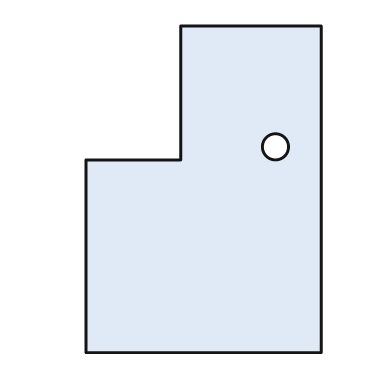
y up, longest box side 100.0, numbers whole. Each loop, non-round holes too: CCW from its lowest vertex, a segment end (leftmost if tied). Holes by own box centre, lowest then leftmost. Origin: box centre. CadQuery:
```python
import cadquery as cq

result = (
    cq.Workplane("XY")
    .moveTo(-36.0, -50.0)
    .lineTo(36.0, -50.0)
    .lineTo(36.0, 50.0)
    .lineTo(-7.0, 50.0)
    .lineTo(-7.0, 9.0)
    .lineTo(-36.0, 9.0)
    .close()
    .moveTo(22.0, 13.0)
    .circle(4.0)
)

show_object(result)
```